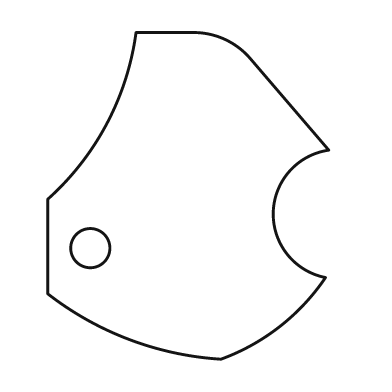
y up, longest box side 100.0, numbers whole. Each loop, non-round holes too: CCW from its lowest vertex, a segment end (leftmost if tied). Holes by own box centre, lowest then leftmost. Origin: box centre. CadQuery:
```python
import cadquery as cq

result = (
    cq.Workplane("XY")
    .moveTo(10.0, -50.0)
    .threePointArc((28.0, -40.0), (42.0, -25.0))
    .threePointArc((26.0, -5.0), (43.0, 14.0))
    .lineTo(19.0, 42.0)
    .threePointArc((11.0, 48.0), (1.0, 50.0))
    .lineTo(-16.0, 50.0)
    .threePointArc((-25.0, 22.0), (-43.0, -1.0))
    .lineTo(-43.0, -30.0)
    .threePointArc((-18.0, -44.0), (10.0, -50.0))
    .close()
    .moveTo(-30.0, -16.0)
    .circle(6.0)
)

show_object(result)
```